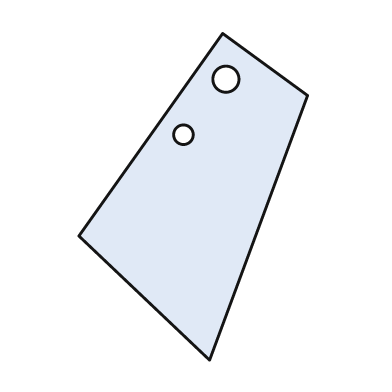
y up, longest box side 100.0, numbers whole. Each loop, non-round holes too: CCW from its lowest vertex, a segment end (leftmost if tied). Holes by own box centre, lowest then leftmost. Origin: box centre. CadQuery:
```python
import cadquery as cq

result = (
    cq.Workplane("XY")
    .moveTo(5.0, -50.0)
    .lineTo(35.0, 31.0)
    .lineTo(9.0, 50.0)
    .lineTo(-35.0, -12.0)
    .close()
    .moveTo(-3.0, 19.0)
    .circle(3.0)
    .moveTo(10.0, 36.0)
    .circle(4.0)
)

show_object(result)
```